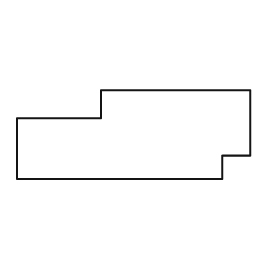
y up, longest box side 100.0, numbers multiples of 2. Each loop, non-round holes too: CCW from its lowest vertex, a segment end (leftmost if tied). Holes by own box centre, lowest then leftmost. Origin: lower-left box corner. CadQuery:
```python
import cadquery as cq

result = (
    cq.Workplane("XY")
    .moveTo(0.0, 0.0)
    .lineTo(88.0, 0.0)
    .lineTo(88.0, 10.0)
    .lineTo(100.0, 10.0)
    .lineTo(100.0, 38.0)
    .lineTo(36.0, 38.0)
    .lineTo(36.0, 26.0)
    .lineTo(0.0, 26.0)
    .close()
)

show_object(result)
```